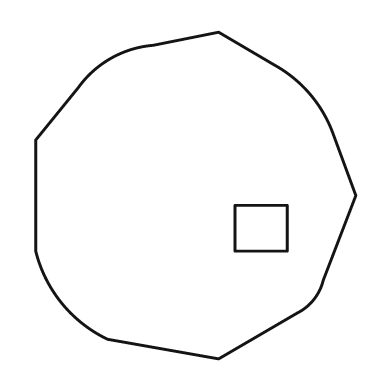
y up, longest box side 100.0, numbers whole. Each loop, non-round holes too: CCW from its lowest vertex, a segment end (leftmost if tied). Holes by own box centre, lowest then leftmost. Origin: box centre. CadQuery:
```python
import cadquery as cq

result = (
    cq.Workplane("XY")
    .moveTo(7.0, -50.0)
    .lineTo(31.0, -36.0)
    .threePointArc((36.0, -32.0), (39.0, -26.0))
    .lineTo(49.0, 0.0)
    .lineTo(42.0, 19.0)
    .threePointArc((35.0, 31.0), (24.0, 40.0))
    .lineTo(7.0, 50.0)
    .lineTo(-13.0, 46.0)
    .threePointArc((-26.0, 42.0), (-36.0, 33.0))
    .lineTo(-49.0, 17.0)
    .lineTo(-49.0, -17.0)
    .threePointArc((-41.0, -33.0), (-27.0, -44.0))
    .close()
    .moveTo(12.0, -17.0)
    .lineTo(28.0, -17.0)
    .lineTo(28.0, -3.0)
    .lineTo(12.0, -3.0)
    .close()
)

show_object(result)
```